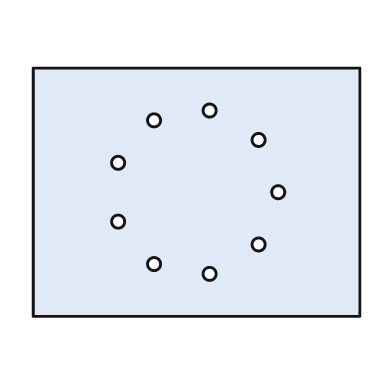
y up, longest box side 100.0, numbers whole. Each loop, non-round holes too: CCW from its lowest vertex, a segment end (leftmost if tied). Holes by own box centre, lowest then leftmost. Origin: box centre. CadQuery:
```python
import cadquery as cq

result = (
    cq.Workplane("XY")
    .moveTo(-50.0, -38.0)
    .lineTo(50.0, -38.0)
    .lineTo(50.0, 38.0)
    .lineTo(-50.0, 38.0)
    .close()
    .moveTo(4.0, -25.0)
    .circle(2.0)
    .moveTo(-13.0, -22.0)
    .circle(2.0)
    .moveTo(19.0, -16.0)
    .circle(2.0)
    .moveTo(-24.0, -9.0)
    .circle(2.0)
    .moveTo(25.0, 0.0)
    .circle(2.0)
    .moveTo(-24.0, 9.0)
    .circle(2.0)
    .moveTo(19.0, 16.0)
    .circle(2.0)
    .moveTo(-13.0, 22.0)
    .circle(2.0)
    .moveTo(4.0, 25.0)
    .circle(2.0)
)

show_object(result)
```